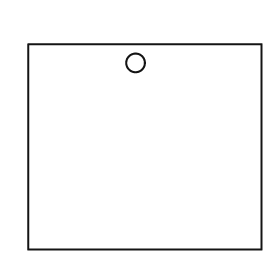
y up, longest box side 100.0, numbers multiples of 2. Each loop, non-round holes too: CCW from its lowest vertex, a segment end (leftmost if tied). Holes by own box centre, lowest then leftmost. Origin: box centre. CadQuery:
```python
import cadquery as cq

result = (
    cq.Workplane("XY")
    .moveTo(-50.0, -44.0)
    .lineTo(50.0, -44.0)
    .lineTo(50.0, 44.0)
    .lineTo(-50.0, 44.0)
    .close()
    .moveTo(-4.0, 36.0)
    .circle(4.0)
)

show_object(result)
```